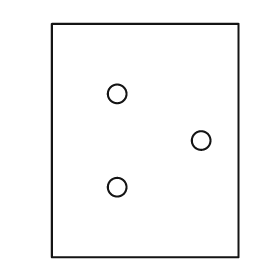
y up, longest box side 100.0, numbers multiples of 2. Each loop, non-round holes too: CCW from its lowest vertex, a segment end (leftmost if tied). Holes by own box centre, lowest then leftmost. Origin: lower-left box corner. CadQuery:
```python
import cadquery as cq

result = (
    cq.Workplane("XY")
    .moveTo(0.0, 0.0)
    .lineTo(80.0, 0.0)
    .lineTo(80.0, 100.0)
    .lineTo(0.0, 100.0)
    .close()
    .moveTo(28.0, 30.0)
    .circle(4.0)
    .moveTo(64.0, 50.0)
    .circle(4.0)
    .moveTo(28.0, 70.0)
    .circle(4.0)
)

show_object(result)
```